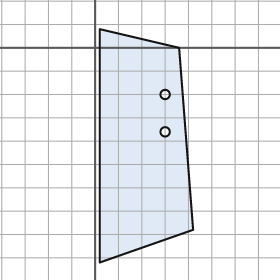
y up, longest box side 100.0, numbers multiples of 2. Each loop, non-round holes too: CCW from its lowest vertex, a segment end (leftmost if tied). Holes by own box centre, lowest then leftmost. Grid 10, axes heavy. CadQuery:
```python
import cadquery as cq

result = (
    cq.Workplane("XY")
    .moveTo(2.0, -92.0)
    .lineTo(42.0, -78.0)
    .lineTo(36.0, 0.0)
    .lineTo(2.0, 8.0)
    .close()
    .moveTo(30.0, -36.0)
    .circle(2.0)
    .moveTo(30.0, -20.0)
    .circle(2.0)
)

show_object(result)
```